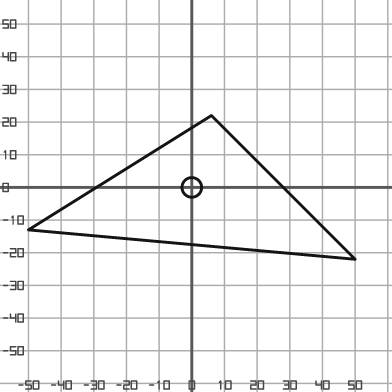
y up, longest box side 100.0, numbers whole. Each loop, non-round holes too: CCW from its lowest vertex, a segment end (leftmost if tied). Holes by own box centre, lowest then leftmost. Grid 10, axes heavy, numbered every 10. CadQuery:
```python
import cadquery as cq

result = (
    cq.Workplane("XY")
    .moveTo(50.0, -22.0)
    .lineTo(6.0, 22.0)
    .lineTo(-50.0, -13.0)
    .close()
    .moveTo(0.0, 0.0)
    .circle(3.0)
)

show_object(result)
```